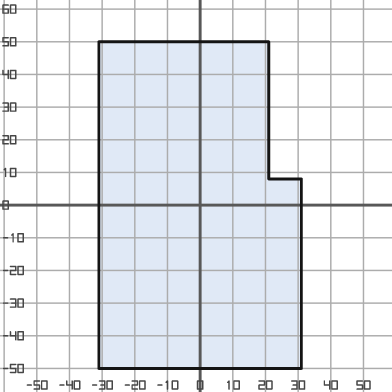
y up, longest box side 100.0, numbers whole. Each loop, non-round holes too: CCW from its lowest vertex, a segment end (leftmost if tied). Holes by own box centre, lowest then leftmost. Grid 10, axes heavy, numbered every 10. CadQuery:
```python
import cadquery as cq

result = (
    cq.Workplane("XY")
    .moveTo(-31.0, -50.0)
    .lineTo(31.0, -50.0)
    .lineTo(31.0, 8.0)
    .lineTo(21.0, 8.0)
    .lineTo(21.0, 50.0)
    .lineTo(-31.0, 50.0)
    .close()
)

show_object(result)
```